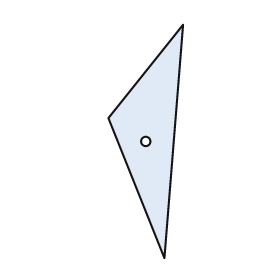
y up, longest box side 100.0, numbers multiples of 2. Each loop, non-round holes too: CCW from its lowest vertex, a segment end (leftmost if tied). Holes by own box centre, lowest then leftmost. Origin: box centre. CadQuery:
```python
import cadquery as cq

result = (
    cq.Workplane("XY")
    .moveTo(8.0, -50.0)
    .lineTo(16.0, 50.0)
    .lineTo(-16.0, 10.0)
    .close()
    .moveTo(0.0, 0.0)
    .circle(2.0)
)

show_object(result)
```